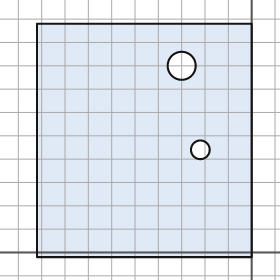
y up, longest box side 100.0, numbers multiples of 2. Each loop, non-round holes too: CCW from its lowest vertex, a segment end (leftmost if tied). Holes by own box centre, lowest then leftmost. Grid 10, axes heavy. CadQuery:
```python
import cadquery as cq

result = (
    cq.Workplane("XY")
    .moveTo(-92.0, -2.0)
    .lineTo(0.0, -2.0)
    .lineTo(0.0, 98.0)
    .lineTo(-92.0, 98.0)
    .close()
    .moveTo(-22.0, 44.0)
    .circle(4.0)
    .moveTo(-30.0, 80.0)
    .circle(6.0)
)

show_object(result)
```